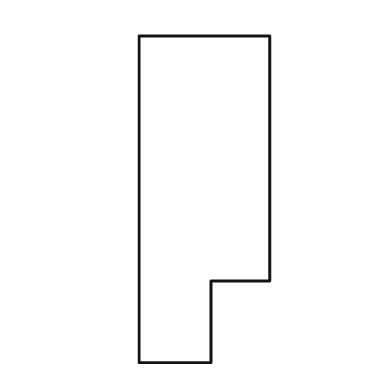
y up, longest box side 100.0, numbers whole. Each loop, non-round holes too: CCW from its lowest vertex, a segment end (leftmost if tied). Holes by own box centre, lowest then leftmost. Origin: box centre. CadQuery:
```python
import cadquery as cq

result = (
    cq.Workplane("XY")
    .moveTo(-20.0, -50.0)
    .lineTo(2.0, -50.0)
    .lineTo(2.0, -25.0)
    .lineTo(20.0, -25.0)
    .lineTo(20.0, 50.0)
    .lineTo(-20.0, 50.0)
    .close()
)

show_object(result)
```